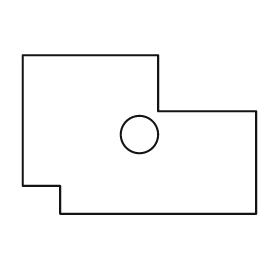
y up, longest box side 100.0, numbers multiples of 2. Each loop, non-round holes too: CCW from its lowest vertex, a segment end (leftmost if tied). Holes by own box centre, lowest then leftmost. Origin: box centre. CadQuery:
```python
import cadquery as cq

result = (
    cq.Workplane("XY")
    .moveTo(-34.0, -34.0)
    .lineTo(50.0, -34.0)
    .lineTo(50.0, 10.0)
    .lineTo(8.0, 10.0)
    .lineTo(8.0, 34.0)
    .lineTo(-50.0, 34.0)
    .lineTo(-50.0, -22.0)
    .lineTo(-34.0, -22.0)
    .close()
    .moveTo(0.0, 0.0)
    .circle(8.0)
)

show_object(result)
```